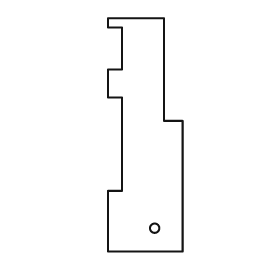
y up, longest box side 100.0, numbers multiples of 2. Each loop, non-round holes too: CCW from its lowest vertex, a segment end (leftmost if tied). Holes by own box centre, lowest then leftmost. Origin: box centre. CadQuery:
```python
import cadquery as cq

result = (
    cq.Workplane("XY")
    .moveTo(-16.0, -50.0)
    .lineTo(16.0, -50.0)
    .lineTo(16.0, 6.0)
    .lineTo(8.0, 6.0)
    .lineTo(8.0, 50.0)
    .lineTo(-16.0, 50.0)
    .lineTo(-16.0, 46.0)
    .lineTo(-10.0, 46.0)
    .lineTo(-10.0, 28.0)
    .lineTo(-16.0, 28.0)
    .lineTo(-16.0, 16.0)
    .lineTo(-10.0, 16.0)
    .lineTo(-10.0, -24.0)
    .lineTo(-16.0, -24.0)
    .close()
    .moveTo(4.0, -40.0)
    .circle(2.0)
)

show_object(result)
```